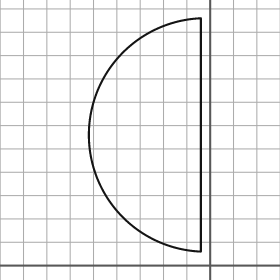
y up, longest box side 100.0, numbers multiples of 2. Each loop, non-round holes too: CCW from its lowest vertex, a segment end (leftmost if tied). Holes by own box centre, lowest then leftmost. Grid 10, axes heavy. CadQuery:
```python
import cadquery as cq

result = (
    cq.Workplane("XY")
    .moveTo(-4.0, 6.0)
    .lineTo(-4.0, 106.0)
    .threePointArc((-52.0, 56.0), (-4.0, 6.0))
    .close()
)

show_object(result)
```